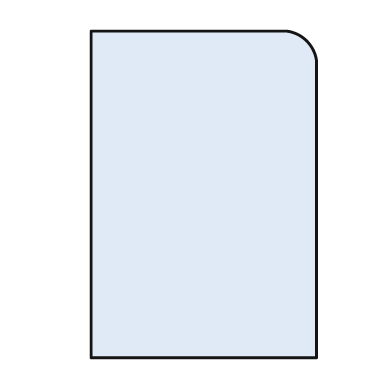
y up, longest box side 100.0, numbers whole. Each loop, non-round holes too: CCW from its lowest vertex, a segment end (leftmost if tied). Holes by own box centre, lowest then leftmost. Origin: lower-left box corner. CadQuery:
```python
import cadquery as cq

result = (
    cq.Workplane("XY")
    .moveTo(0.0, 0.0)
    .lineTo(69.0, 0.0)
    .lineTo(69.0, 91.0)
    .threePointArc((66.0, 97.0), (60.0, 100.0))
    .lineTo(0.0, 100.0)
    .close()
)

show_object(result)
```